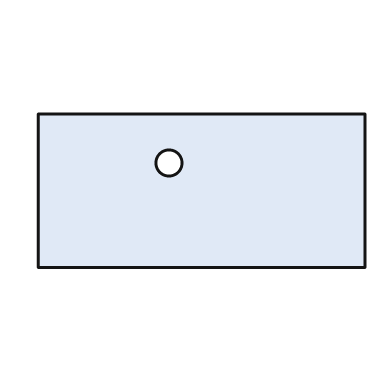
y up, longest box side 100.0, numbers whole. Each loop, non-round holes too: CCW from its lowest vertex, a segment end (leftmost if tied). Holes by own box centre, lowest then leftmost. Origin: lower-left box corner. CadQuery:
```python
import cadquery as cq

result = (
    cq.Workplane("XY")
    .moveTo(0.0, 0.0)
    .lineTo(100.0, 0.0)
    .lineTo(100.0, 47.0)
    .lineTo(0.0, 47.0)
    .close()
    .moveTo(40.0, 32.0)
    .circle(4.0)
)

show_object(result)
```